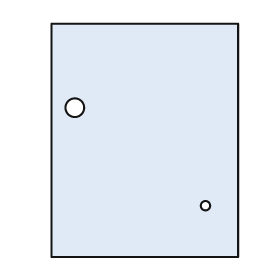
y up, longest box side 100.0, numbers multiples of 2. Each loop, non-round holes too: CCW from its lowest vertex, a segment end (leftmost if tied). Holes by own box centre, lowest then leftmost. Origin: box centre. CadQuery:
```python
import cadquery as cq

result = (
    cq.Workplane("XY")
    .moveTo(-40.0, -50.0)
    .lineTo(40.0, -50.0)
    .lineTo(40.0, 50.0)
    .lineTo(-40.0, 50.0)
    .close()
    .moveTo(26.0, -28.0)
    .circle(2.0)
    .moveTo(-30.0, 14.0)
    .circle(4.0)
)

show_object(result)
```